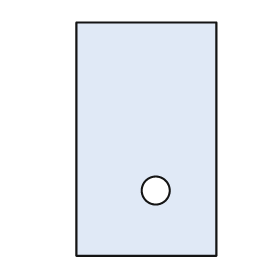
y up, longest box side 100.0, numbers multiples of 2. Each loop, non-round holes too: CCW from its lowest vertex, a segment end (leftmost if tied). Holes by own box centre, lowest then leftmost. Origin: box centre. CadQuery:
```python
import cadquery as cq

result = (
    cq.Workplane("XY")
    .moveTo(-30.0, -50.0)
    .lineTo(30.0, -50.0)
    .lineTo(30.0, 50.0)
    .lineTo(-30.0, 50.0)
    .close()
    .moveTo(4.0, -22.0)
    .circle(6.0)
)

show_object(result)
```